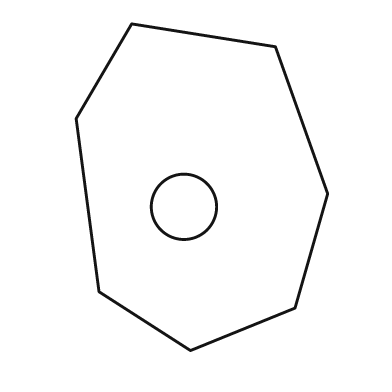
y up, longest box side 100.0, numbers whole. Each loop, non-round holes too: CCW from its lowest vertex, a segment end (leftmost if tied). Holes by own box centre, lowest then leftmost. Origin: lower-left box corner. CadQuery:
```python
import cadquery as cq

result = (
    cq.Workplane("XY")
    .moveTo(35.0, 0.0)
    .lineTo(67.0, 13.0)
    .lineTo(77.0, 48.0)
    .lineTo(61.0, 93.0)
    .lineTo(17.0, 100.0)
    .lineTo(0.0, 71.0)
    .lineTo(7.0, 18.0)
    .close()
    .moveTo(33.0, 44.0)
    .circle(10.0)
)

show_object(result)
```